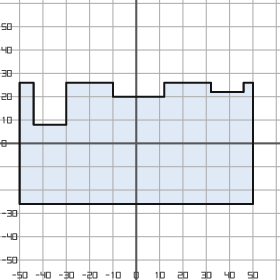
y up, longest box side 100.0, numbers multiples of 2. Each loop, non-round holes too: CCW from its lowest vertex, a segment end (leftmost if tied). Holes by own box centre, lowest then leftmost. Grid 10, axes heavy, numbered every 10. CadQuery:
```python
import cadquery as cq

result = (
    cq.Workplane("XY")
    .moveTo(-50.0, -26.0)
    .lineTo(50.0, -26.0)
    .lineTo(50.0, 26.0)
    .lineTo(46.0, 26.0)
    .lineTo(46.0, 22.0)
    .lineTo(32.0, 22.0)
    .lineTo(32.0, 26.0)
    .lineTo(12.0, 26.0)
    .lineTo(12.0, 20.0)
    .lineTo(-10.0, 20.0)
    .lineTo(-10.0, 26.0)
    .lineTo(-30.0, 26.0)
    .lineTo(-30.0, 8.0)
    .lineTo(-44.0, 8.0)
    .lineTo(-44.0, 26.0)
    .lineTo(-50.0, 26.0)
    .close()
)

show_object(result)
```